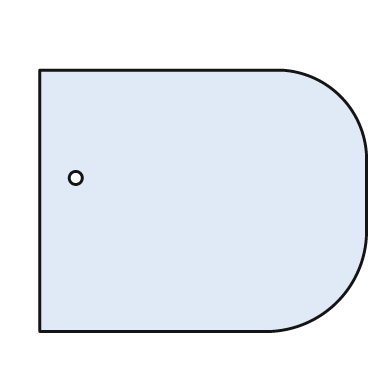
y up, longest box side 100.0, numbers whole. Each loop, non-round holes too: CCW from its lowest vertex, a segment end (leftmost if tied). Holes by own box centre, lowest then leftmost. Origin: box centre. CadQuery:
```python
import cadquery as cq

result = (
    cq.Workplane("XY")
    .moveTo(-50.0, -40.0)
    .lineTo(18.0, -40.0)
    .threePointArc((41.0, -31.0), (50.0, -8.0))
    .lineTo(50.0, 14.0)
    .threePointArc((42.0, 32.0), (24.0, 40.0))
    .lineTo(-50.0, 40.0)
    .close()
    .moveTo(-39.0, 7.0)
    .circle(2.0)
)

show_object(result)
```